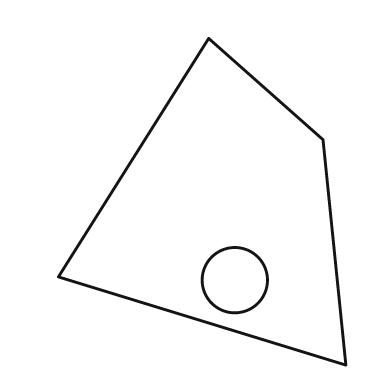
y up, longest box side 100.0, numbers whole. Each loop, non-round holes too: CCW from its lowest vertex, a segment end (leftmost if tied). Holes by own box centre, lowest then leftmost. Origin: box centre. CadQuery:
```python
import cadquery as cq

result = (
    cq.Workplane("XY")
    .moveTo(44.0, -50.0)
    .lineTo(37.0, 19.0)
    .lineTo(2.0, 50.0)
    .lineTo(-44.0, -23.0)
    .close()
    .moveTo(10.0, -24.0)
    .circle(10.0)
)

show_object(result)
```